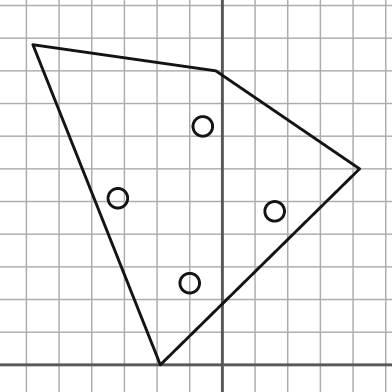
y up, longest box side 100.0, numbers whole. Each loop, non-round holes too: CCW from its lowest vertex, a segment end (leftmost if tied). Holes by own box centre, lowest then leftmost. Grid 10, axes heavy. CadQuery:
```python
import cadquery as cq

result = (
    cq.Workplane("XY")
    .moveTo(-19.0, 0.0)
    .lineTo(42.0, 60.0)
    .lineTo(-2.0, 90.0)
    .lineTo(-58.0, 98.0)
    .close()
    .moveTo(-10.0, 25.0)
    .circle(3.0)
    .moveTo(16.0, 47.0)
    .circle(3.0)
    .moveTo(-32.0, 51.0)
    .circle(3.0)
    .moveTo(-6.0, 73.0)
    .circle(3.0)
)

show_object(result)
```